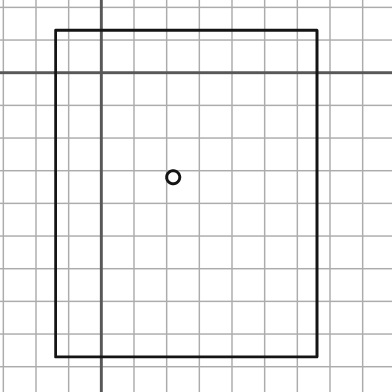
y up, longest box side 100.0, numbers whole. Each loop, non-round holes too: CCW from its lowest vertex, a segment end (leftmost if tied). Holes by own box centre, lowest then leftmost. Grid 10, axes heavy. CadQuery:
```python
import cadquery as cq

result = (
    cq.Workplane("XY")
    .moveTo(-14.0, -87.0)
    .lineTo(66.0, -87.0)
    .lineTo(66.0, 13.0)
    .lineTo(-14.0, 13.0)
    .close()
    .moveTo(22.0, -32.0)
    .circle(2.0)
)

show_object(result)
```